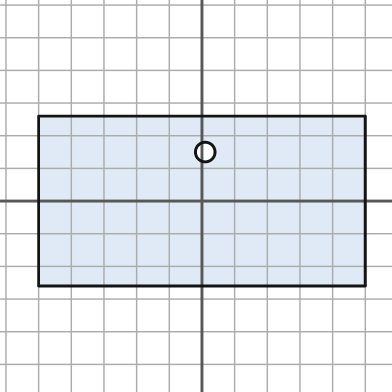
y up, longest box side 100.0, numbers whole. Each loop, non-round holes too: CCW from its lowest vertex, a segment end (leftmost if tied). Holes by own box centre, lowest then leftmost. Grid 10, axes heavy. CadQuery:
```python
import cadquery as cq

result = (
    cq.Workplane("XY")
    .moveTo(-50.0, -26.0)
    .lineTo(50.0, -26.0)
    .lineTo(50.0, 26.0)
    .lineTo(-50.0, 26.0)
    .close()
    .moveTo(1.0, 15.0)
    .circle(3.0)
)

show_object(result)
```